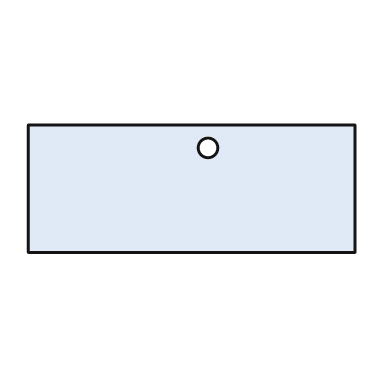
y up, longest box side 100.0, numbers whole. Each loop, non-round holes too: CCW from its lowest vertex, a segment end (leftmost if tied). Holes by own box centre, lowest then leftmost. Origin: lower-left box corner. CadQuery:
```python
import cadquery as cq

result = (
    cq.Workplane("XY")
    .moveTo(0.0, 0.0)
    .lineTo(100.0, 0.0)
    .lineTo(100.0, 39.0)
    .lineTo(0.0, 39.0)
    .close()
    .moveTo(55.0, 32.0)
    .circle(3.0)
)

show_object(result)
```